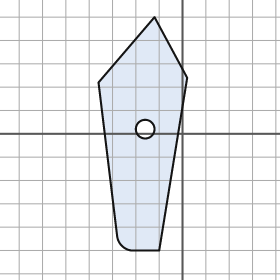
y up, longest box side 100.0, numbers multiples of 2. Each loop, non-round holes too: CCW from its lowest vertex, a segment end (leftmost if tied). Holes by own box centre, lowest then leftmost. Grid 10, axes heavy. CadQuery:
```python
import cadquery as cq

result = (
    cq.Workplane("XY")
    .moveTo(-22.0, -50.0)
    .lineTo(-10.0, -50.0)
    .lineTo(2.0, 24.0)
    .lineTo(-12.0, 50.0)
    .lineTo(-36.0, 22.0)
    .lineTo(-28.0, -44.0)
    .threePointArc((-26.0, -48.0), (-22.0, -50.0))
    .close()
    .moveTo(-16.0, 2.0)
    .circle(4.0)
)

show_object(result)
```